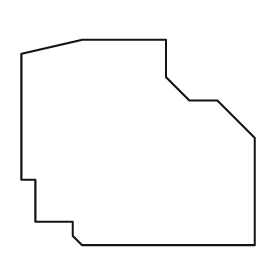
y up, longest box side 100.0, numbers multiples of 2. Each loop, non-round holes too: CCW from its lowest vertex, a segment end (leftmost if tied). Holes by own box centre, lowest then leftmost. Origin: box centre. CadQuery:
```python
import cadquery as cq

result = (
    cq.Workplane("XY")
    .moveTo(-24.0, -44.0)
    .lineTo(50.0, -44.0)
    .lineTo(50.0, 2.0)
    .lineTo(34.0, 18.0)
    .lineTo(22.0, 18.0)
    .lineTo(12.0, 28.0)
    .lineTo(12.0, 44.0)
    .lineTo(-24.0, 44.0)
    .lineTo(-50.0, 38.0)
    .lineTo(-50.0, -16.0)
    .lineTo(-44.0, -16.0)
    .lineTo(-44.0, -34.0)
    .lineTo(-28.0, -34.0)
    .lineTo(-28.0, -40.0)
    .close()
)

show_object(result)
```